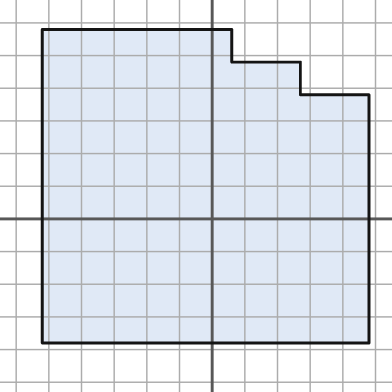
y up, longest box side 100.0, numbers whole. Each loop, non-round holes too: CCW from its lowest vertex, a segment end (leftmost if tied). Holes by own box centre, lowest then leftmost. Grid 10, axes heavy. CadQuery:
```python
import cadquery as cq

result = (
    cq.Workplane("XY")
    .moveTo(-52.0, -38.0)
    .lineTo(48.0, -38.0)
    .lineTo(48.0, 38.0)
    .lineTo(27.0, 38.0)
    .lineTo(27.0, 48.0)
    .lineTo(6.0, 48.0)
    .lineTo(6.0, 58.0)
    .lineTo(-52.0, 58.0)
    .close()
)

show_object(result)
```